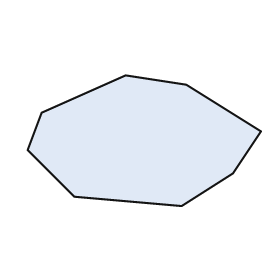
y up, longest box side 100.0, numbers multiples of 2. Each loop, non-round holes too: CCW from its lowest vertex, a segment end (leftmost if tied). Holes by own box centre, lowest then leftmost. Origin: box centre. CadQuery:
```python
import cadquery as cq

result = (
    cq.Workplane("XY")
    .moveTo(16.0, -28.0)
    .lineTo(38.0, -14.0)
    .lineTo(50.0, 4.0)
    .lineTo(18.0, 24.0)
    .lineTo(-8.0, 28.0)
    .lineTo(-44.0, 12.0)
    .lineTo(-50.0, -4.0)
    .lineTo(-30.0, -24.0)
    .close()
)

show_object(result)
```